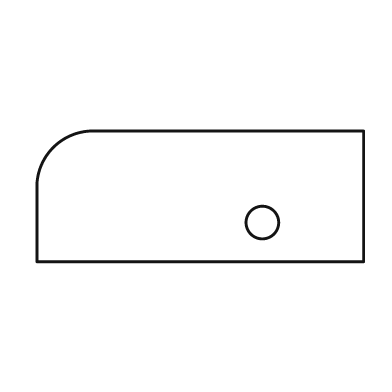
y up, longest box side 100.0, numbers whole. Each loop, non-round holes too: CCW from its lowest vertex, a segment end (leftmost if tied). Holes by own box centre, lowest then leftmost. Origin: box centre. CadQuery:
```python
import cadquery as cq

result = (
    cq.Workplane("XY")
    .moveTo(-50.0, -20.0)
    .lineTo(50.0, -20.0)
    .lineTo(50.0, 20.0)
    .lineTo(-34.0, 20.0)
    .threePointArc((-45.0, 15.0), (-50.0, 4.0))
    .close()
    .moveTo(19.0, -8.0)
    .circle(5.0)
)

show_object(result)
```